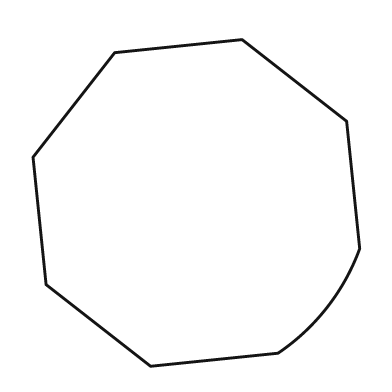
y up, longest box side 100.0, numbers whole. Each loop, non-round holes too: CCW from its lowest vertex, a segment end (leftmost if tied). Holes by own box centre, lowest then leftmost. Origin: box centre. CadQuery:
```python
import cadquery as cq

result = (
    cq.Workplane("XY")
    .moveTo(-14.0, -50.0)
    .lineTo(25.0, -46.0)
    .threePointArc((40.0, -32.0), (50.0, -14.0))
    .lineTo(46.0, 25.0)
    .lineTo(14.0, 50.0)
    .lineTo(-25.0, 46.0)
    .lineTo(-50.0, 14.0)
    .lineTo(-46.0, -25.0)
    .close()
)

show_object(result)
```